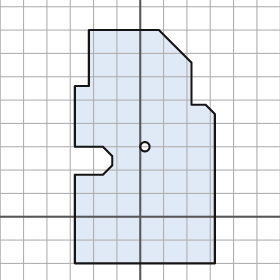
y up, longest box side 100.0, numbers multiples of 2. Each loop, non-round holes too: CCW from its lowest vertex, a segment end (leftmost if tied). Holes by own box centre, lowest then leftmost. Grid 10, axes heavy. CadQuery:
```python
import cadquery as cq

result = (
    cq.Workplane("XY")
    .moveTo(-28.0, -20.0)
    .lineTo(32.0, -20.0)
    .lineTo(32.0, 44.0)
    .lineTo(28.0, 48.0)
    .lineTo(22.0, 48.0)
    .lineTo(22.0, 66.0)
    .lineTo(8.0, 80.0)
    .lineTo(-22.0, 80.0)
    .lineTo(-22.0, 56.0)
    .lineTo(-28.0, 56.0)
    .lineTo(-28.0, 30.0)
    .lineTo(-16.0, 30.0)
    .lineTo(-12.0, 26.0)
    .lineTo(-12.0, 22.0)
    .lineTo(-16.0, 18.0)
    .lineTo(-28.0, 18.0)
    .close()
    .moveTo(2.0, 30.0)
    .circle(2.0)
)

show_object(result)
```